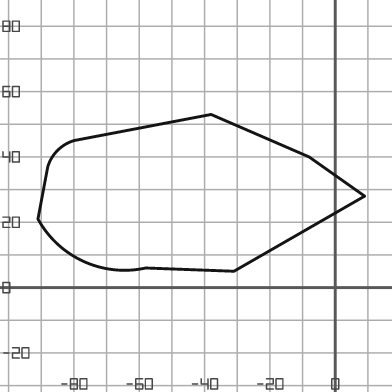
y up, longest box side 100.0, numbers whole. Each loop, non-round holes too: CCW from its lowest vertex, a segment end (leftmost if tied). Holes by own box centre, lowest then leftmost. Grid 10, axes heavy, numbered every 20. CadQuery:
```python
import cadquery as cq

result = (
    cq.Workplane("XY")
    .moveTo(-31.0, 5.0)
    .lineTo(9.0, 28.0)
    .lineTo(-8.0, 40.0)
    .lineTo(-38.0, 53.0)
    .lineTo(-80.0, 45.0)
    .threePointArc((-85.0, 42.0), (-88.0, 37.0))
    .lineTo(-91.0, 21.0)
    .threePointArc((-77.0, 8.0), (-58.0, 6.0))
    .close()
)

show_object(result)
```